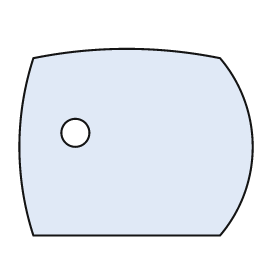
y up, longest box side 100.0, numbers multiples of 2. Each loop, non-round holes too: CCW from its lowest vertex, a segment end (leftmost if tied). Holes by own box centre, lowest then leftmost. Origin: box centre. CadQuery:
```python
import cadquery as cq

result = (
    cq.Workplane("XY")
    .moveTo(-44.0, -40.0)
    .lineTo(36.0, -40.0)
    .threePointArc((50.0, -2.0), (36.0, 36.0))
    .threePointArc((-4.0, 40.0), (-44.0, 36.0))
    .threePointArc((-50.0, -2.0), (-44.0, -40.0))
    .close()
    .moveTo(-26.0, 4.0)
    .circle(6.0)
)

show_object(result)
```